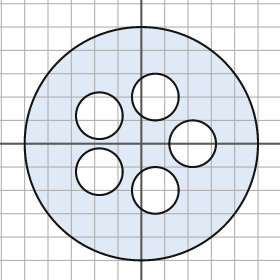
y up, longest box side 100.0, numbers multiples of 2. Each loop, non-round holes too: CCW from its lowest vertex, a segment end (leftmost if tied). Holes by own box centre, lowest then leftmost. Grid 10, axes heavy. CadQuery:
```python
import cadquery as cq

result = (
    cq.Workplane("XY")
    .moveTo(0.0, 0.0)
    .circle(50.0)
    .moveTo(6.0, -20.0)
    .circle(10.0)
    .moveTo(-18.0, -12.0)
    .circle(10.0)
    .moveTo(22.0, 0.0)
    .circle(10.0)
    .moveTo(-18.0, 12.0)
    .circle(10.0)
    .moveTo(6.0, 20.0)
    .circle(10.0)
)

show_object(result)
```